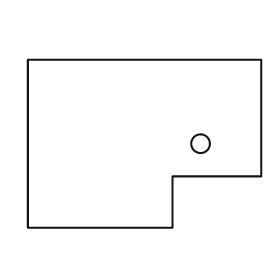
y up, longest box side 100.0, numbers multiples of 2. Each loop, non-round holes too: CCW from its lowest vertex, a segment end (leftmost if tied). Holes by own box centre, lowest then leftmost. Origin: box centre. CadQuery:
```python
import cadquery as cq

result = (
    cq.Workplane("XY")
    .moveTo(-50.0, -36.0)
    .lineTo(12.0, -36.0)
    .lineTo(12.0, -14.0)
    .lineTo(50.0, -14.0)
    .lineTo(50.0, 36.0)
    .lineTo(-50.0, 36.0)
    .close()
    .moveTo(24.0, 0.0)
    .circle(4.0)
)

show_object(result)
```